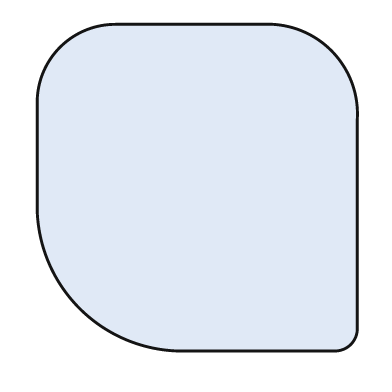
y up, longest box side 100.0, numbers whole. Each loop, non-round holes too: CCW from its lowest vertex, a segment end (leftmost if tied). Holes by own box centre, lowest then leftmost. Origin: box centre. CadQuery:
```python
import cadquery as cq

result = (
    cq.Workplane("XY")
    .moveTo(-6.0, -50.0)
    .lineTo(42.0, -50.0)
    .threePointArc((47.0, -48.0), (49.0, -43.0))
    .lineTo(49.0, 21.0)
    .threePointArc((41.0, 42.0), (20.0, 50.0))
    .lineTo(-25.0, 50.0)
    .threePointArc((-42.0, 43.0), (-49.0, 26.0))
    .lineTo(-49.0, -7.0)
    .threePointArc((-36.0, -37.0), (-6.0, -50.0))
    .close()
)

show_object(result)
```